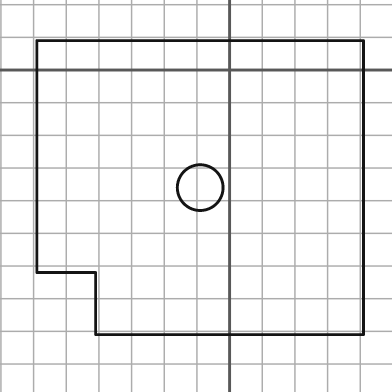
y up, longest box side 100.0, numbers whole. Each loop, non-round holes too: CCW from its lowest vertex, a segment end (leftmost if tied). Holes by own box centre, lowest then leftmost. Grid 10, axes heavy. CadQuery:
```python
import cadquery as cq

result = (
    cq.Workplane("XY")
    .moveTo(-41.0, -81.0)
    .lineTo(41.0, -81.0)
    .lineTo(41.0, 9.0)
    .lineTo(-59.0, 9.0)
    .lineTo(-59.0, -62.0)
    .lineTo(-41.0, -62.0)
    .close()
    .moveTo(-9.0, -36.0)
    .circle(7.0)
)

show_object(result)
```